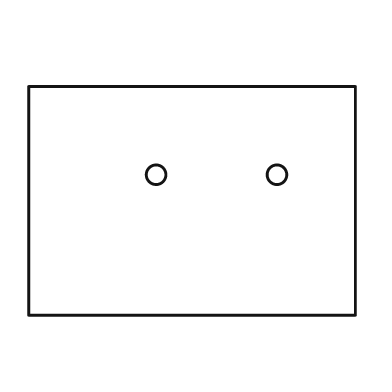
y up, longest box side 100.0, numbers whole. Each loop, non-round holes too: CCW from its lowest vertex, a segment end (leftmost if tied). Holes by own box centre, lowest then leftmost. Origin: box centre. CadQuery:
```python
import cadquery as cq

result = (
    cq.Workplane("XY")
    .moveTo(-50.0, -35.0)
    .lineTo(50.0, -35.0)
    .lineTo(50.0, 35.0)
    .lineTo(-50.0, 35.0)
    .close()
    .moveTo(-11.0, 8.0)
    .circle(3.0)
    .moveTo(26.0, 8.0)
    .circle(3.0)
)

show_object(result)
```